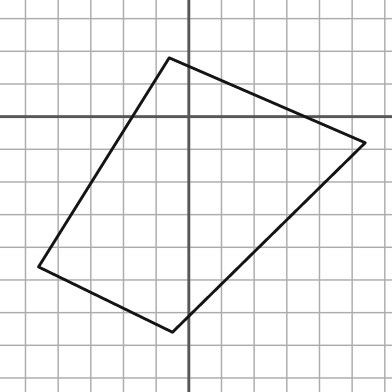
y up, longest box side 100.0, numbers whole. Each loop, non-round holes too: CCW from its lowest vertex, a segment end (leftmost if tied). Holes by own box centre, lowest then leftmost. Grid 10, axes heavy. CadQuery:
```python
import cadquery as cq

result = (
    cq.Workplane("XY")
    .moveTo(-5.0, -66.0)
    .lineTo(54.0, -8.0)
    .lineTo(-6.0, 18.0)
    .lineTo(-46.0, -46.0)
    .close()
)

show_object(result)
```